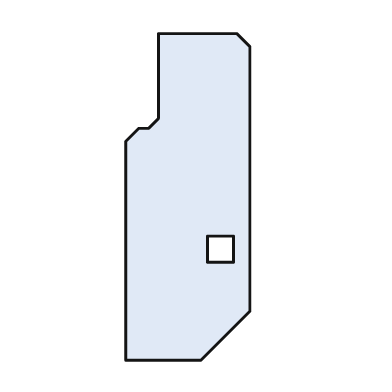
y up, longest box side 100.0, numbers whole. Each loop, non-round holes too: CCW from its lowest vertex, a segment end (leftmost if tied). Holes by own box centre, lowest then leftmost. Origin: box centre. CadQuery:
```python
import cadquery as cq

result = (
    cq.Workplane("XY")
    .moveTo(-19.0, -50.0)
    .lineTo(4.0, -50.0)
    .lineTo(19.0, -35.0)
    .lineTo(19.0, 46.0)
    .lineTo(15.0, 50.0)
    .lineTo(-9.0, 50.0)
    .lineTo(-9.0, 24.0)
    .lineTo(-12.0, 21.0)
    .lineTo(-15.0, 21.0)
    .lineTo(-19.0, 17.0)
    .close()
    .moveTo(6.0, -20.0)
    .lineTo(14.0, -20.0)
    .lineTo(14.0, -12.0)
    .lineTo(6.0, -12.0)
    .close()
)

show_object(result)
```